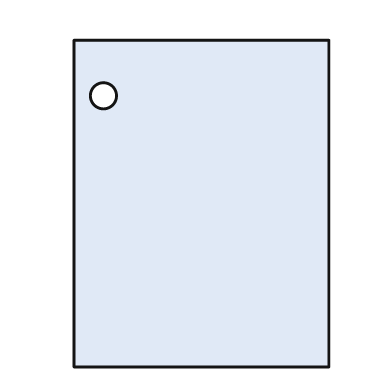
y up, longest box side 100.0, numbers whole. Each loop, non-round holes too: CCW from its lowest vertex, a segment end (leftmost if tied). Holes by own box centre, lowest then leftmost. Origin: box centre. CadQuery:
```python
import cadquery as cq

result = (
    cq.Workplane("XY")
    .moveTo(-39.0, -50.0)
    .lineTo(39.0, -50.0)
    .lineTo(39.0, 50.0)
    .lineTo(-39.0, 50.0)
    .close()
    .moveTo(-30.0, 33.0)
    .circle(4.0)
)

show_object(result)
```